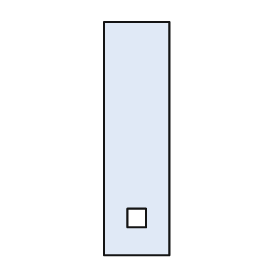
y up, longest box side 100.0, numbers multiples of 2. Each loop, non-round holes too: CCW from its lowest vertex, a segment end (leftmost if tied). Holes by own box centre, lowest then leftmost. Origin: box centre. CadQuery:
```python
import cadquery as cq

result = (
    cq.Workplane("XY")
    .moveTo(-14.0, -50.0)
    .lineTo(14.0, -50.0)
    .lineTo(14.0, 50.0)
    .lineTo(-14.0, 50.0)
    .close()
    .moveTo(-4.0, -38.0)
    .lineTo(4.0, -38.0)
    .lineTo(4.0, -30.0)
    .lineTo(-4.0, -30.0)
    .close()
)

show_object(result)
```